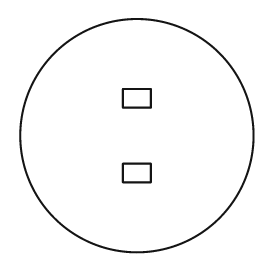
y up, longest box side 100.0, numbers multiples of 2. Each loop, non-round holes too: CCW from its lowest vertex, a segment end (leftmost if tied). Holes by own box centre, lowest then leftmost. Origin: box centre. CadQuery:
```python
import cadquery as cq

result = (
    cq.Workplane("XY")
    .moveTo(0.0, 0.0)
    .circle(50.0)
    .moveTo(-6.0, -20.0)
    .lineTo(6.0, -20.0)
    .lineTo(6.0, -12.0)
    .lineTo(-6.0, -12.0)
    .close()
    .moveTo(-6.0, 12.0)
    .lineTo(6.0, 12.0)
    .lineTo(6.0, 20.0)
    .lineTo(-6.0, 20.0)
    .close()
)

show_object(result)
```